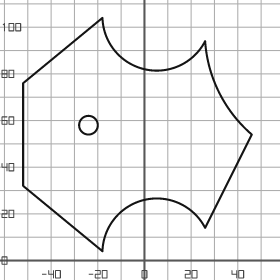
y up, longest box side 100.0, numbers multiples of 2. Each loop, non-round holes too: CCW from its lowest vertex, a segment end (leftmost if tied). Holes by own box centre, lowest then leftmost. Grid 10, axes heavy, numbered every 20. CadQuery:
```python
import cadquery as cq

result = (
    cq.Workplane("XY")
    .moveTo(-18.0, 4.0)
    .threePointArc((0.0, 26.0), (26.0, 14.0))
    .lineTo(46.0, 54.0)
    .threePointArc((32.0, 72.0), (26.0, 94.0))
    .threePointArc((0.0, 82.0), (-18.0, 104.0))
    .lineTo(-52.0, 76.0)
    .lineTo(-52.0, 32.0)
    .close()
    .moveTo(-24.0, 58.0)
    .circle(4.0)
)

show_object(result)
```